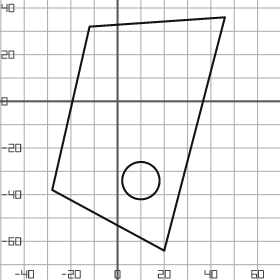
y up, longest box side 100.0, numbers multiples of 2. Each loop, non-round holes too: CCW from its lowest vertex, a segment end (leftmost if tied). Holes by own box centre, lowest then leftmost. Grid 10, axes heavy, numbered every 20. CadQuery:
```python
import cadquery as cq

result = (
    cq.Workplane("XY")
    .moveTo(20.0, -64.0)
    .lineTo(46.0, 36.0)
    .lineTo(-12.0, 32.0)
    .lineTo(-28.0, -38.0)
    .close()
    .moveTo(10.0, -34.0)
    .circle(8.0)
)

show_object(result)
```